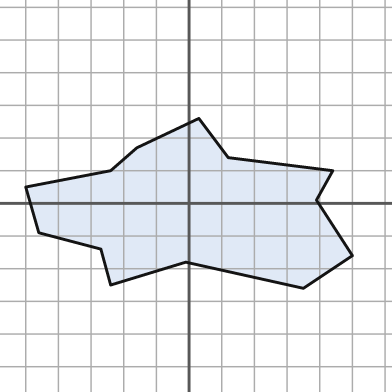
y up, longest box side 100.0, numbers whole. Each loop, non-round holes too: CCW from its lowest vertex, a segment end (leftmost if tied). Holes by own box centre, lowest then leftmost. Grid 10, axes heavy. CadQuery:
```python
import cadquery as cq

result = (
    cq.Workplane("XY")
    .moveTo(35.0, -26.0)
    .lineTo(50.0, -16.0)
    .lineTo(39.0, 1.0)
    .lineTo(44.0, 10.0)
    .lineTo(12.0, 14.0)
    .lineTo(3.0, 26.0)
    .lineTo(-16.0, 17.0)
    .lineTo(-24.0, 10.0)
    .lineTo(-50.0, 5.0)
    .lineTo(-46.0, -9.0)
    .lineTo(-27.0, -14.0)
    .lineTo(-24.0, -25.0)
    .lineTo(-1.0, -18.0)
    .close()
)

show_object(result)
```